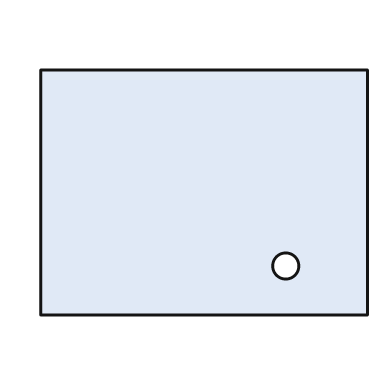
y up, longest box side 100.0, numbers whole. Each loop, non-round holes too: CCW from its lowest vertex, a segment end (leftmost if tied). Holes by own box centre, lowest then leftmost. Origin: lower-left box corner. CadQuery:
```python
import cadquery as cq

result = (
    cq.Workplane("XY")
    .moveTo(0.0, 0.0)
    .lineTo(100.0, 0.0)
    .lineTo(100.0, 75.0)
    .lineTo(0.0, 75.0)
    .close()
    .moveTo(75.0, 15.0)
    .circle(4.0)
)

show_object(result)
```